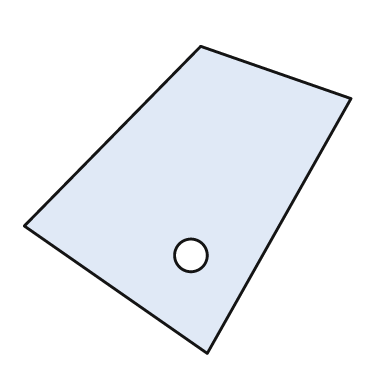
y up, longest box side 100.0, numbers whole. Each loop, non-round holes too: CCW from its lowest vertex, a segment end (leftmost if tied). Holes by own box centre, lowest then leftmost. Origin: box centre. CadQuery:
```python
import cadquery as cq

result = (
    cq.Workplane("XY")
    .moveTo(6.0, -47.0)
    .lineTo(50.0, 31.0)
    .lineTo(4.0, 47.0)
    .lineTo(-50.0, -8.0)
    .close()
    .moveTo(1.0, -17.0)
    .circle(5.0)
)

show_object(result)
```